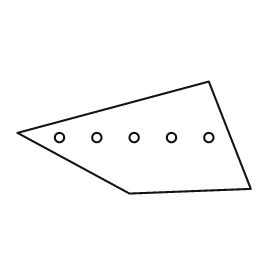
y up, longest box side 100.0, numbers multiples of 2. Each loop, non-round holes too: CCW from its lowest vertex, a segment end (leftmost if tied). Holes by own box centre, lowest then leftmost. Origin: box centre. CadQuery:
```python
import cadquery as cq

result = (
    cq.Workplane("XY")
    .moveTo(-2.0, -24.0)
    .lineTo(50.0, -22.0)
    .lineTo(32.0, 24.0)
    .lineTo(-50.0, 2.0)
    .close()
    .moveTo(-32.0, 0.0)
    .circle(2.0)
    .moveTo(-16.0, 0.0)
    .circle(2.0)
    .moveTo(0.0, 0.0)
    .circle(2.0)
    .moveTo(16.0, 0.0)
    .circle(2.0)
    .moveTo(32.0, 0.0)
    .circle(2.0)
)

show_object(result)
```